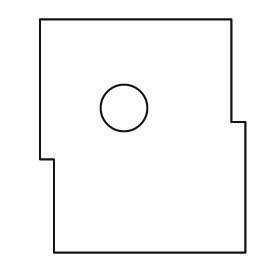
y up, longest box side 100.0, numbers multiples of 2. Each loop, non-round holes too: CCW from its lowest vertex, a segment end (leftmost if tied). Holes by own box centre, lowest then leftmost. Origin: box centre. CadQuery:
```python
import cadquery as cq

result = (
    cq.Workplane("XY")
    .moveTo(-38.0, -50.0)
    .lineTo(44.0, -50.0)
    .lineTo(44.0, 6.0)
    .lineTo(38.0, 6.0)
    .lineTo(38.0, 50.0)
    .lineTo(-44.0, 50.0)
    .lineTo(-44.0, -10.0)
    .lineTo(-38.0, -10.0)
    .close()
    .moveTo(-8.0, 12.0)
    .circle(10.0)
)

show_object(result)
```